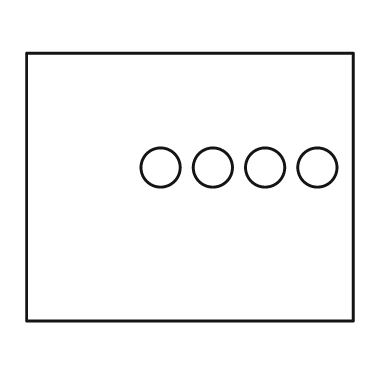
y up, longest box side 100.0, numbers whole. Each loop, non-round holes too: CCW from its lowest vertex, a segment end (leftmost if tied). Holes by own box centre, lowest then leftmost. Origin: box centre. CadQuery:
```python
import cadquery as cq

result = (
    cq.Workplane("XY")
    .moveTo(-50.0, -41.0)
    .lineTo(50.0, -41.0)
    .lineTo(50.0, 41.0)
    .lineTo(-50.0, 41.0)
    .close()
    .moveTo(-9.0, 6.0)
    .circle(6.0)
    .moveTo(7.0, 6.0)
    .circle(6.0)
    .moveTo(23.0, 6.0)
    .circle(6.0)
    .moveTo(39.0, 6.0)
    .circle(6.0)
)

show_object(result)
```